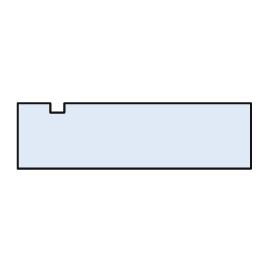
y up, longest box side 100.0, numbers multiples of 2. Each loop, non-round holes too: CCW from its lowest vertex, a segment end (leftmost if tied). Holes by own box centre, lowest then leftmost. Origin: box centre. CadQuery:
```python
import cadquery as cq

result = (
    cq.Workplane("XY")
    .moveTo(-50.0, -14.0)
    .lineTo(50.0, -14.0)
    .lineTo(50.0, 14.0)
    .lineTo(-30.0, 14.0)
    .lineTo(-30.0, 10.0)
    .lineTo(-36.0, 10.0)
    .lineTo(-36.0, 14.0)
    .lineTo(-50.0, 14.0)
    .close()
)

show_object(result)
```